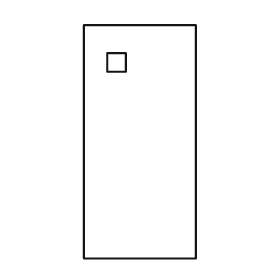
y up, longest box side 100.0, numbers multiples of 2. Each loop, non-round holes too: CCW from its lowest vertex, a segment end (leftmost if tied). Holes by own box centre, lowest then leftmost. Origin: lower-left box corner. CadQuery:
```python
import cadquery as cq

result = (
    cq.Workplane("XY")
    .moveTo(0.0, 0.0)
    .lineTo(48.0, 0.0)
    .lineTo(48.0, 100.0)
    .lineTo(0.0, 100.0)
    .close()
    .moveTo(10.0, 80.0)
    .lineTo(18.0, 80.0)
    .lineTo(18.0, 88.0)
    .lineTo(10.0, 88.0)
    .close()
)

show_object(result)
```